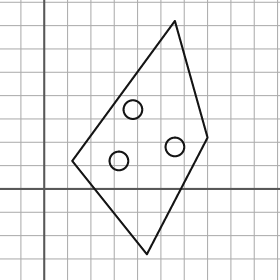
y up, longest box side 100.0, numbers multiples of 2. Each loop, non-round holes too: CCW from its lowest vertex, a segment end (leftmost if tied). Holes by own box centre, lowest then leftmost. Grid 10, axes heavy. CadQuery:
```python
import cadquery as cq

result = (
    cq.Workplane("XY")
    .moveTo(44.0, -28.0)
    .lineTo(70.0, 22.0)
    .lineTo(56.0, 72.0)
    .lineTo(12.0, 12.0)
    .close()
    .moveTo(32.0, 12.0)
    .circle(4.0)
    .moveTo(56.0, 18.0)
    .circle(4.0)
    .moveTo(38.0, 34.0)
    .circle(4.0)
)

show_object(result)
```